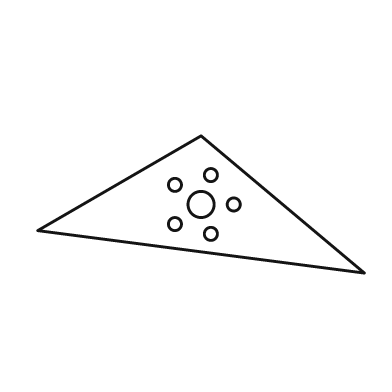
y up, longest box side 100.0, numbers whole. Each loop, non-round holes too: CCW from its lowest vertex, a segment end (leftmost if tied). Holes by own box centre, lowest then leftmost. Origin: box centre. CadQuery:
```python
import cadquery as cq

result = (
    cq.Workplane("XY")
    .moveTo(50.0, -21.0)
    .lineTo(0.0, 21.0)
    .lineTo(-50.0, -8.0)
    .close()
    .moveTo(3.0, -9.0)
    .circle(2.0)
    .moveTo(-8.0, -6.0)
    .circle(2.0)
    .moveTo(0.0, 0.0)
    .circle(4.0)
    .moveTo(10.0, 0.0)
    .circle(2.0)
    .moveTo(-8.0, 6.0)
    .circle(2.0)
    .moveTo(3.0, 9.0)
    .circle(2.0)
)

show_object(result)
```